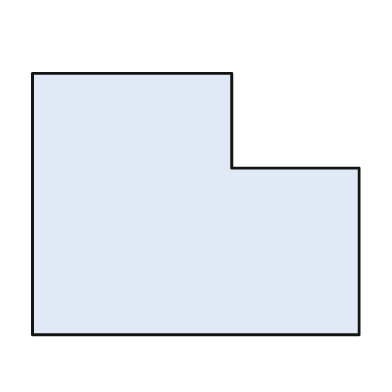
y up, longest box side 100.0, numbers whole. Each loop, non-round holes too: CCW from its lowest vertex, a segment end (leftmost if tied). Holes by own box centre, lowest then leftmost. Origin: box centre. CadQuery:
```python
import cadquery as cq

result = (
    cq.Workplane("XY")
    .moveTo(-50.0, -40.0)
    .lineTo(50.0, -40.0)
    .lineTo(50.0, 11.0)
    .lineTo(11.0, 11.0)
    .lineTo(11.0, 40.0)
    .lineTo(-50.0, 40.0)
    .close()
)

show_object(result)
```